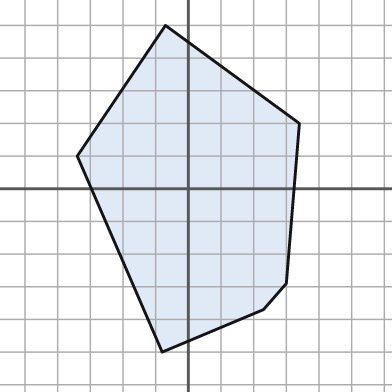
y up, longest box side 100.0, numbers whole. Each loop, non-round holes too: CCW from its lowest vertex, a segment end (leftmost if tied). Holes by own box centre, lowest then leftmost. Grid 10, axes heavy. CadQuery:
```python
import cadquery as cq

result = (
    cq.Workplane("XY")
    .moveTo(-8.0, -50.0)
    .lineTo(23.0, -37.0)
    .lineTo(30.0, -29.0)
    .lineTo(34.0, 20.0)
    .lineTo(-7.0, 50.0)
    .lineTo(-34.0, 10.0)
    .close()
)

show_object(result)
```